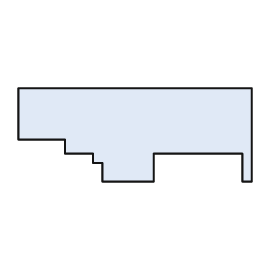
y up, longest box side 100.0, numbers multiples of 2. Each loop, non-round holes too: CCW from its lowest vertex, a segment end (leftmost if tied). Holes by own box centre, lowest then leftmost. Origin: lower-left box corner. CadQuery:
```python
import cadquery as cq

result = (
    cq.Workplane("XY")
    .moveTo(36.0, 0.0)
    .lineTo(58.0, 0.0)
    .lineTo(58.0, 12.0)
    .lineTo(96.0, 12.0)
    .lineTo(96.0, 0.0)
    .lineTo(100.0, 0.0)
    .lineTo(100.0, 40.0)
    .lineTo(0.0, 40.0)
    .lineTo(0.0, 18.0)
    .lineTo(20.0, 18.0)
    .lineTo(20.0, 12.0)
    .lineTo(32.0, 12.0)
    .lineTo(32.0, 8.0)
    .lineTo(36.0, 8.0)
    .close()
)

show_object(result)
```